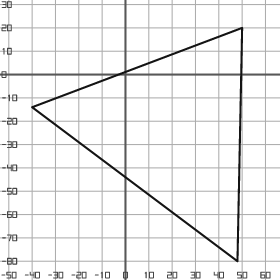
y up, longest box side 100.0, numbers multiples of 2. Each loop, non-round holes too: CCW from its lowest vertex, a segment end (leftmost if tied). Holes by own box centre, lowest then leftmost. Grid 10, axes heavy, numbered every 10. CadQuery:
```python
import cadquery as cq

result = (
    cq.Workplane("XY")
    .moveTo(48.0, -80.0)
    .lineTo(50.0, 20.0)
    .lineTo(-40.0, -14.0)
    .close()
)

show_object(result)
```